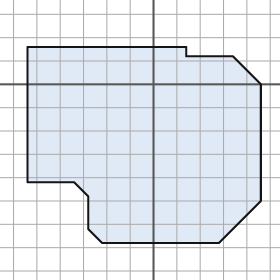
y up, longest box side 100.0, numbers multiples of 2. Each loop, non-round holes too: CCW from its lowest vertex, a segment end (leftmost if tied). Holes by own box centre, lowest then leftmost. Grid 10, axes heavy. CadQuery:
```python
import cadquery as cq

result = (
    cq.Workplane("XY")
    .moveTo(-22.0, -68.0)
    .lineTo(28.0, -68.0)
    .lineTo(46.0, -50.0)
    .lineTo(46.0, 0.0)
    .lineTo(34.0, 12.0)
    .lineTo(14.0, 12.0)
    .lineTo(14.0, 16.0)
    .lineTo(-54.0, 16.0)
    .lineTo(-54.0, -42.0)
    .lineTo(-34.0, -42.0)
    .lineTo(-28.0, -48.0)
    .lineTo(-28.0, -62.0)
    .close()
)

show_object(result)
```